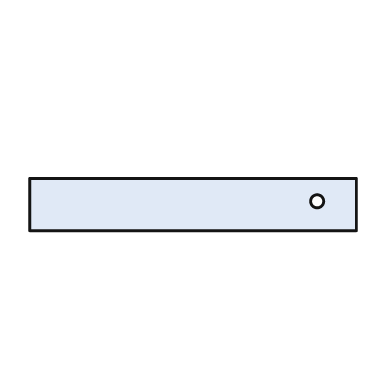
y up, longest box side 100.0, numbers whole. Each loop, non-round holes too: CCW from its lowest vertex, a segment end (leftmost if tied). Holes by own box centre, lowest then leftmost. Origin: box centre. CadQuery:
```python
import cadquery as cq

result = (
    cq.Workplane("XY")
    .moveTo(-50.0, -8.0)
    .lineTo(50.0, -8.0)
    .lineTo(50.0, 8.0)
    .lineTo(-50.0, 8.0)
    .close()
    .moveTo(38.0, 1.0)
    .circle(2.0)
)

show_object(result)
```